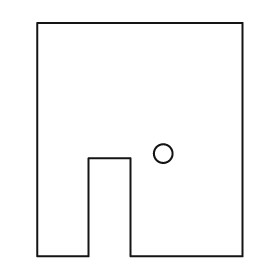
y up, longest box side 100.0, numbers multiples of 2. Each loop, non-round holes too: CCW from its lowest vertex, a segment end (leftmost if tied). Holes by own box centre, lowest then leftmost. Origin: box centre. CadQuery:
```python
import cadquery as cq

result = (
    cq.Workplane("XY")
    .moveTo(-44.0, -50.0)
    .lineTo(-22.0, -50.0)
    .lineTo(-22.0, -8.0)
    .lineTo(-4.0, -8.0)
    .lineTo(-4.0, -50.0)
    .lineTo(44.0, -50.0)
    .lineTo(44.0, 50.0)
    .lineTo(-44.0, 50.0)
    .close()
    .moveTo(10.0, -6.0)
    .circle(4.0)
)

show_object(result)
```